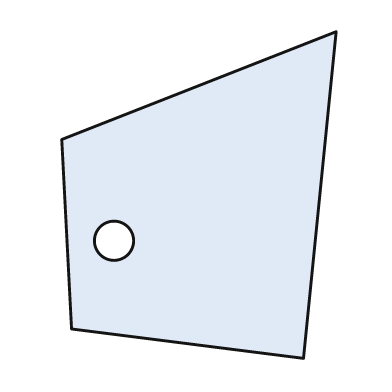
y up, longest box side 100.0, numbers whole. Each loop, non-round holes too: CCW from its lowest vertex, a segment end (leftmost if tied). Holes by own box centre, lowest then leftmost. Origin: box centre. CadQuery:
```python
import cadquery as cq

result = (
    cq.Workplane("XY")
    .moveTo(32.0, -50.0)
    .lineTo(42.0, 50.0)
    .lineTo(-42.0, 17.0)
    .lineTo(-39.0, -41.0)
    .close()
    .moveTo(-26.0, -14.0)
    .circle(6.0)
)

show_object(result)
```